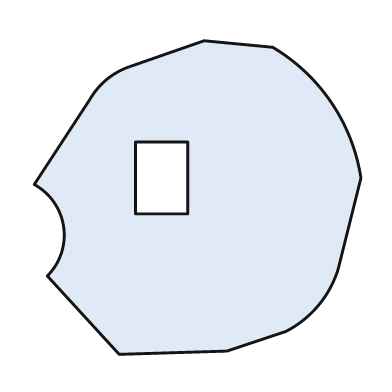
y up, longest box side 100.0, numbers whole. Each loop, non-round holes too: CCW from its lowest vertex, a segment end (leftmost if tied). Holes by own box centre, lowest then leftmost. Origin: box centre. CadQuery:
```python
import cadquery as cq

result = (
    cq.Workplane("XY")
    .moveTo(-24.0, -48.0)
    .lineTo(9.0, -47.0)
    .lineTo(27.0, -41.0)
    .threePointArc((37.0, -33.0), (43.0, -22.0))
    .lineTo(50.0, 6.0)
    .threePointArc((41.0, 29.0), (23.0, 46.0))
    .lineTo(2.0, 48.0)
    .lineTo(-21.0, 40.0)
    .threePointArc((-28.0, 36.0), (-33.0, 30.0))
    .lineTo(-50.0, 4.0)
    .threePointArc((-41.0, -9.0), (-46.0, -24.0))
    .close()
    .moveTo(-19.0, -5.0)
    .lineTo(-3.0, -5.0)
    .lineTo(-3.0, 17.0)
    .lineTo(-19.0, 17.0)
    .close()
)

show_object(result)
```